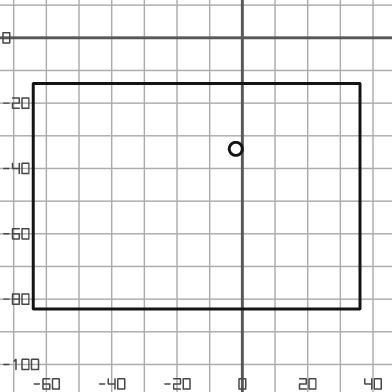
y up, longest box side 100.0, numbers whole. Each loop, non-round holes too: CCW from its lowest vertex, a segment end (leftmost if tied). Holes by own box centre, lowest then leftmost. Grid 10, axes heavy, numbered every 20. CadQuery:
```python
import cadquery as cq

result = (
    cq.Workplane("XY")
    .moveTo(-64.0, -83.0)
    .lineTo(36.0, -83.0)
    .lineTo(36.0, -14.0)
    .lineTo(-64.0, -14.0)
    .close()
    .moveTo(-2.0, -34.0)
    .circle(2.0)
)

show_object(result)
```